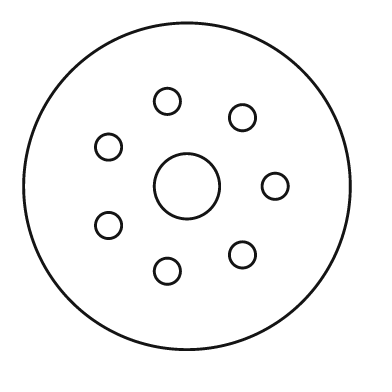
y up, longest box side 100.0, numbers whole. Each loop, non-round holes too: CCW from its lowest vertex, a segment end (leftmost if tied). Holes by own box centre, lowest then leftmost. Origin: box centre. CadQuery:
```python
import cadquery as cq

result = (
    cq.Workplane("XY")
    .moveTo(0.0, 0.0)
    .circle(50.0)
    .moveTo(-6.0, -26.0)
    .circle(4.0)
    .moveTo(17.0, -21.0)
    .circle(4.0)
    .moveTo(-24.0, -12.0)
    .circle(4.0)
    .moveTo(0.0, 0.0)
    .circle(10.0)
    .moveTo(27.0, 0.0)
    .circle(4.0)
    .moveTo(-24.0, 12.0)
    .circle(4.0)
    .moveTo(17.0, 21.0)
    .circle(4.0)
    .moveTo(-6.0, 26.0)
    .circle(4.0)
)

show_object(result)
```